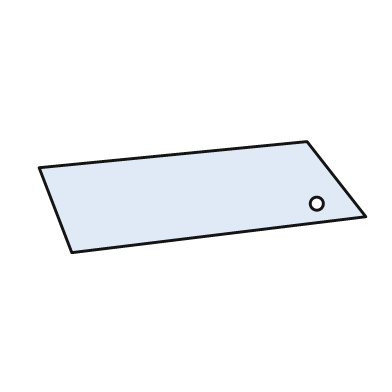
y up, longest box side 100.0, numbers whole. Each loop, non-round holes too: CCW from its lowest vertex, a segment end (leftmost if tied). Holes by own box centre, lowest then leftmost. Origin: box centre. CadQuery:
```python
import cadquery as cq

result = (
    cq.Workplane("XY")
    .moveTo(-40.0, -17.0)
    .lineTo(50.0, -6.0)
    .lineTo(32.0, 17.0)
    .lineTo(-50.0, 9.0)
    .close()
    .moveTo(35.0, -2.0)
    .circle(2.0)
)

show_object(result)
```